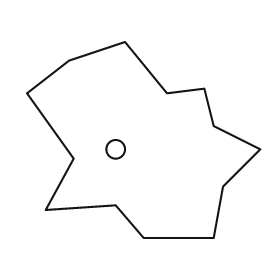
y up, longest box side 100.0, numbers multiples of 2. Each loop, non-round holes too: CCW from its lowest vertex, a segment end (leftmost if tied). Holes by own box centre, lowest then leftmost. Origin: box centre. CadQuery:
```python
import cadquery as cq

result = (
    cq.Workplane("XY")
    .moveTo(0.0, -42.0)
    .lineTo(30.0, -42.0)
    .lineTo(34.0, -20.0)
    .lineTo(50.0, -4.0)
    .lineTo(30.0, 6.0)
    .lineTo(26.0, 22.0)
    .lineTo(10.0, 20.0)
    .lineTo(-8.0, 42.0)
    .lineTo(-32.0, 34.0)
    .lineTo(-50.0, 20.0)
    .lineTo(-30.0, -8.0)
    .lineTo(-42.0, -30.0)
    .lineTo(-12.0, -28.0)
    .close()
    .moveTo(-12.0, -4.0)
    .circle(4.0)
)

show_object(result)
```